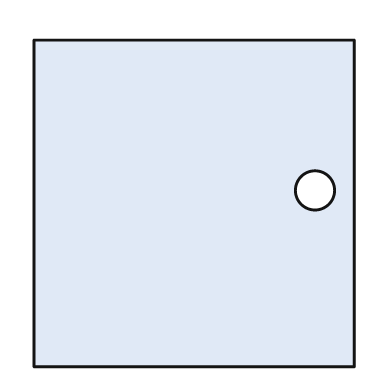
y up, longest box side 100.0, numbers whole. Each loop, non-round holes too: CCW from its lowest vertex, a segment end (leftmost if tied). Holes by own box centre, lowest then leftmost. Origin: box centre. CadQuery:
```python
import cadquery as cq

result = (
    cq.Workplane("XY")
    .moveTo(-49.0, -50.0)
    .lineTo(49.0, -50.0)
    .lineTo(49.0, 50.0)
    .lineTo(-49.0, 50.0)
    .close()
    .moveTo(37.0, 4.0)
    .circle(6.0)
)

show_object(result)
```